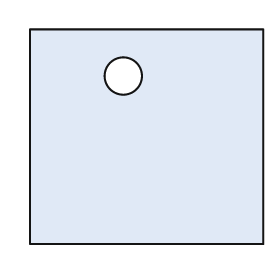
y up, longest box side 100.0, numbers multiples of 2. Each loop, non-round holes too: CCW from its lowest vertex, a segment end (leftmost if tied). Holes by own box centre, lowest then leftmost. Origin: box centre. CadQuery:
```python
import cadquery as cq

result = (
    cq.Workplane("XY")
    .moveTo(-50.0, -46.0)
    .lineTo(50.0, -46.0)
    .lineTo(50.0, 46.0)
    .lineTo(-50.0, 46.0)
    .close()
    .moveTo(-10.0, 26.0)
    .circle(8.0)
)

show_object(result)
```